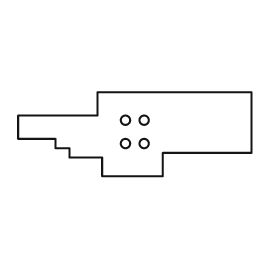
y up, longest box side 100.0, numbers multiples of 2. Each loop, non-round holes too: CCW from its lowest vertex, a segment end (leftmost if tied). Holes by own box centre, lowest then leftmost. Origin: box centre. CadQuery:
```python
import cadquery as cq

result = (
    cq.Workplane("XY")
    .moveTo(-14.0, -18.0)
    .lineTo(12.0, -18.0)
    .lineTo(12.0, -8.0)
    .lineTo(50.0, -8.0)
    .lineTo(50.0, 18.0)
    .lineTo(-16.0, 18.0)
    .lineTo(-16.0, 8.0)
    .lineTo(-50.0, 8.0)
    .lineTo(-50.0, -2.0)
    .lineTo(-34.0, -2.0)
    .lineTo(-34.0, -6.0)
    .lineTo(-28.0, -6.0)
    .lineTo(-28.0, -10.0)
    .lineTo(-14.0, -10.0)
    .close()
    .moveTo(-4.0, -4.0)
    .circle(2.0)
    .moveTo(4.0, -4.0)
    .circle(2.0)
    .moveTo(-4.0, 6.0)
    .circle(2.0)
    .moveTo(4.0, 6.0)
    .circle(2.0)
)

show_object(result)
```